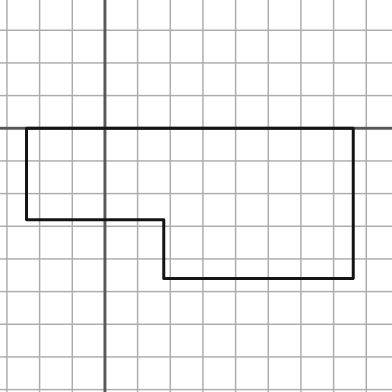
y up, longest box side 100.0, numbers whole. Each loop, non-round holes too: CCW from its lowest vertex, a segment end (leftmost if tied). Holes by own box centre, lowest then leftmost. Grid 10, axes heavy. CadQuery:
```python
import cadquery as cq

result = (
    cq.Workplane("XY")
    .moveTo(18.0, -46.0)
    .lineTo(76.0, -46.0)
    .lineTo(76.0, 0.0)
    .lineTo(-24.0, 0.0)
    .lineTo(-24.0, -28.0)
    .lineTo(18.0, -28.0)
    .close()
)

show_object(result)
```